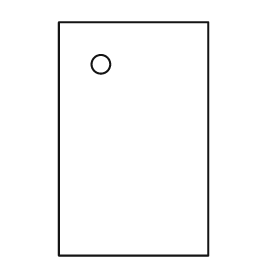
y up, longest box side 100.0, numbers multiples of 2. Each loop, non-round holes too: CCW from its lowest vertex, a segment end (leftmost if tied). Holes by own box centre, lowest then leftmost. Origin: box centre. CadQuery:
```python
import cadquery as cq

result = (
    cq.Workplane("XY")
    .moveTo(-32.0, -50.0)
    .lineTo(32.0, -50.0)
    .lineTo(32.0, 50.0)
    .lineTo(-32.0, 50.0)
    .close()
    .moveTo(-14.0, 32.0)
    .circle(4.0)
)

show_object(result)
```